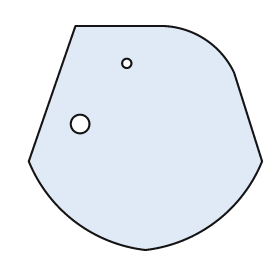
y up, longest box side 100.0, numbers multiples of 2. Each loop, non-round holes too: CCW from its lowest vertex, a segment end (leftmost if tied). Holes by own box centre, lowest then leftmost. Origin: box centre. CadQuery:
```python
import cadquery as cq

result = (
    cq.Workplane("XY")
    .moveTo(0.0, -48.0)
    .threePointArc((30.0, -36.0), (50.0, -10.0))
    .lineTo(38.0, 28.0)
    .threePointArc((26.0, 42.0), (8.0, 48.0))
    .lineTo(-30.0, 48.0)
    .lineTo(-50.0, -10.0)
    .threePointArc((-30.0, -36.0), (0.0, -48.0))
    .close()
    .moveTo(-28.0, 6.0)
    .circle(4.0)
    .moveTo(-8.0, 32.0)
    .circle(2.0)
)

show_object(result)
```